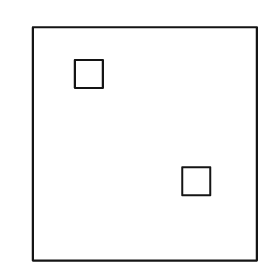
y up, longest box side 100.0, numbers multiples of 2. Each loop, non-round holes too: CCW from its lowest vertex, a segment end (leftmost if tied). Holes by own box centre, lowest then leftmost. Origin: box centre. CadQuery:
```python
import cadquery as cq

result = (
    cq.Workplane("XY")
    .moveTo(-48.0, -50.0)
    .lineTo(48.0, -50.0)
    .lineTo(48.0, 50.0)
    .lineTo(-48.0, 50.0)
    .close()
    .moveTo(16.0, -22.0)
    .lineTo(28.0, -22.0)
    .lineTo(28.0, -10.0)
    .lineTo(16.0, -10.0)
    .close()
    .moveTo(-30.0, 24.0)
    .lineTo(-18.0, 24.0)
    .lineTo(-18.0, 36.0)
    .lineTo(-30.0, 36.0)
    .close()
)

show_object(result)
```